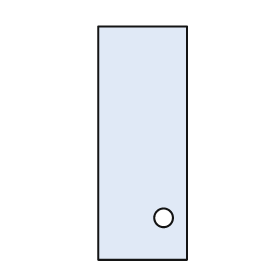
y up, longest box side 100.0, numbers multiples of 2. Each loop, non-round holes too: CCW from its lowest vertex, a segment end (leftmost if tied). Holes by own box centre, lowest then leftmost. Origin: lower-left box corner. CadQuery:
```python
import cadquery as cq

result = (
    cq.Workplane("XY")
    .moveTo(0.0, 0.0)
    .lineTo(38.0, 0.0)
    .lineTo(38.0, 100.0)
    .lineTo(0.0, 100.0)
    .close()
    .moveTo(28.0, 18.0)
    .circle(4.0)
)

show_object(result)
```